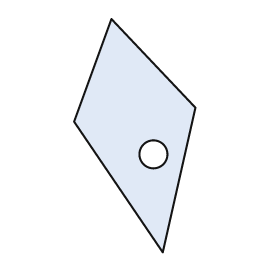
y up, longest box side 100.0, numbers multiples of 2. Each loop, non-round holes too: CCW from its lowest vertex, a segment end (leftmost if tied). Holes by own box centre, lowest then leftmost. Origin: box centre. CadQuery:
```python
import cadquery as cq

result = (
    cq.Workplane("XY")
    .moveTo(12.0, -50.0)
    .lineTo(26.0, 12.0)
    .lineTo(-10.0, 50.0)
    .lineTo(-26.0, 6.0)
    .close()
    .moveTo(8.0, -8.0)
    .circle(6.0)
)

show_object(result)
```